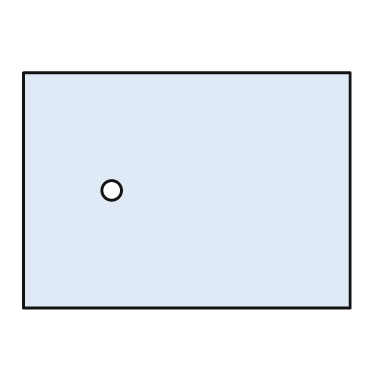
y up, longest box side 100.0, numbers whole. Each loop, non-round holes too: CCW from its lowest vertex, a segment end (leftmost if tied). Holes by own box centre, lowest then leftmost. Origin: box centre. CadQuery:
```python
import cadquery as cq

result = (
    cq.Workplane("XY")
    .moveTo(-50.0, -36.0)
    .lineTo(50.0, -36.0)
    .lineTo(50.0, 36.0)
    .lineTo(-50.0, 36.0)
    .close()
    .moveTo(-23.0, 0.0)
    .circle(3.0)
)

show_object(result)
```